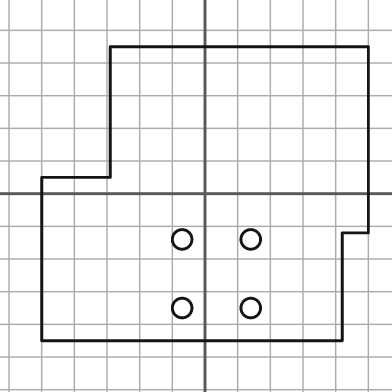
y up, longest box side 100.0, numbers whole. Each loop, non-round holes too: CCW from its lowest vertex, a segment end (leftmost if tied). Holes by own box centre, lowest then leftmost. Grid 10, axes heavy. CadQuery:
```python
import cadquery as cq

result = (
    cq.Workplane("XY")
    .moveTo(-50.0, -45.0)
    .lineTo(42.0, -45.0)
    .lineTo(42.0, -12.0)
    .lineTo(50.0, -12.0)
    .lineTo(50.0, 45.0)
    .lineTo(-29.0, 45.0)
    .lineTo(-29.0, 5.0)
    .lineTo(-50.0, 5.0)
    .close()
    .moveTo(-7.0, -35.0)
    .circle(3.0)
    .moveTo(14.0, -35.0)
    .circle(3.0)
    .moveTo(-7.0, -14.0)
    .circle(3.0)
    .moveTo(14.0, -14.0)
    .circle(3.0)
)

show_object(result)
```